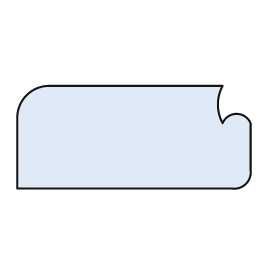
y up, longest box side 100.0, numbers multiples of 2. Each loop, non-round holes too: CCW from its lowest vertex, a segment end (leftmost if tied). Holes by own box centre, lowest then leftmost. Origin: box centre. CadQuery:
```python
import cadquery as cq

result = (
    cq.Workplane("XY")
    .moveTo(-50.0, -22.0)
    .lineTo(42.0, -22.0)
    .threePointArc((48.0, -20.0), (50.0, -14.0))
    .lineTo(50.0, 6.0)
    .threePointArc((44.0, 10.0), (38.0, 6.0))
    .threePointArc((36.0, 14.0), (38.0, 22.0))
    .lineTo(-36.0, 22.0)
    .threePointArc((-46.0, 18.0), (-50.0, 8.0))
    .close()
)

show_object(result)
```